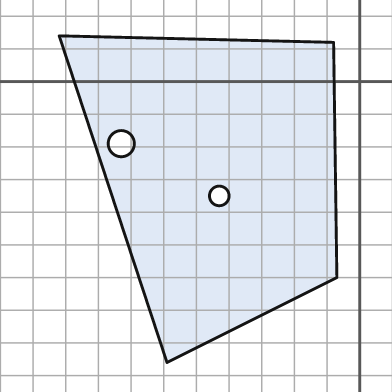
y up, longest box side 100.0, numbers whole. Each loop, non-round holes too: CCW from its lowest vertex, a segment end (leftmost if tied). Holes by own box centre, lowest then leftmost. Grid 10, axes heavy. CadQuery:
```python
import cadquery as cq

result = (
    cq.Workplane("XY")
    .moveTo(-59.0, -86.0)
    .lineTo(-7.0, -60.0)
    .lineTo(-8.0, 12.0)
    .lineTo(-92.0, 14.0)
    .close()
    .moveTo(-43.0, -35.0)
    .circle(3.0)
    .moveTo(-73.0, -19.0)
    .circle(4.0)
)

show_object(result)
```